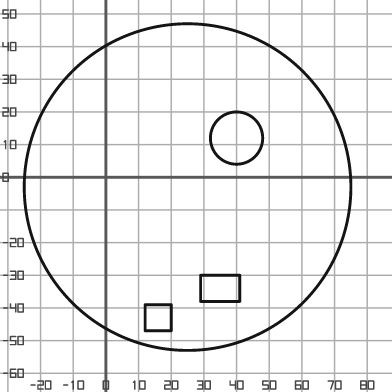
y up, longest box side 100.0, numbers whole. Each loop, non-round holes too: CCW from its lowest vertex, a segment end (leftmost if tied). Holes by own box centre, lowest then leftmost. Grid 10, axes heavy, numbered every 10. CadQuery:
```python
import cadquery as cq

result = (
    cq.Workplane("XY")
    .moveTo(25.0, -3.0)
    .circle(50.0)
    .moveTo(12.0, -47.0)
    .lineTo(20.0, -47.0)
    .lineTo(20.0, -39.0)
    .lineTo(12.0, -39.0)
    .close()
    .moveTo(29.0, -38.0)
    .lineTo(41.0, -38.0)
    .lineTo(41.0, -30.0)
    .lineTo(29.0, -30.0)
    .close()
    .moveTo(40.0, 12.0)
    .circle(8.0)
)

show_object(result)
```